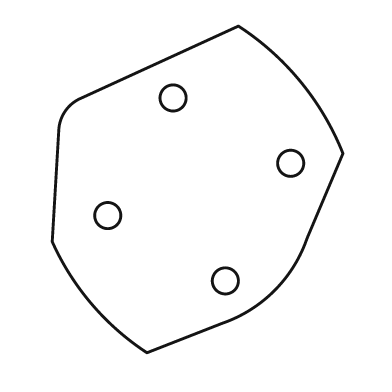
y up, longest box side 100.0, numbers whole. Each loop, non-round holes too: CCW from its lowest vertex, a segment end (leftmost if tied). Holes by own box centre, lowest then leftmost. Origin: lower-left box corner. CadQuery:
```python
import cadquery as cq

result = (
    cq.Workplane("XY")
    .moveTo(29.0, 0.0)
    .lineTo(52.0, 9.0)
    .threePointArc((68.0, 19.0), (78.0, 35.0))
    .lineTo(89.0, 61.0)
    .threePointArc((76.0, 83.0), (57.0, 100.0))
    .lineTo(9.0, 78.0)
    .threePointArc((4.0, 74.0), (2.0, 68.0))
    .lineTo(0.0, 34.0)
    .threePointArc((12.0, 15.0), (29.0, 0.0))
    .close()
    .moveTo(53.0, 22.0)
    .circle(4.0)
    .moveTo(17.0, 42.0)
    .circle(4.0)
    .moveTo(73.0, 58.0)
    .circle(4.0)
    .moveTo(37.0, 78.0)
    .circle(4.0)
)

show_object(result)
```